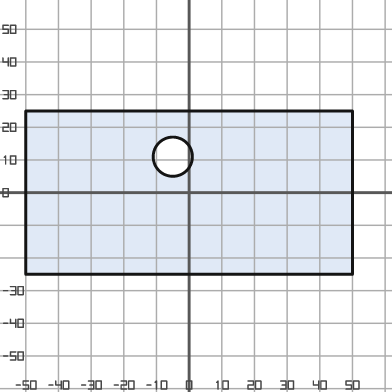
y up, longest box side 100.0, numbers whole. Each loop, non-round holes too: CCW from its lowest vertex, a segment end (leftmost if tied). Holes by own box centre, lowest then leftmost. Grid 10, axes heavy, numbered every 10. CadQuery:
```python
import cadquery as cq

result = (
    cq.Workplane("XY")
    .moveTo(-50.0, -25.0)
    .lineTo(50.0, -25.0)
    .lineTo(50.0, 25.0)
    .lineTo(-50.0, 25.0)
    .close()
    .moveTo(-5.0, 11.0)
    .circle(6.0)
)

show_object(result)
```